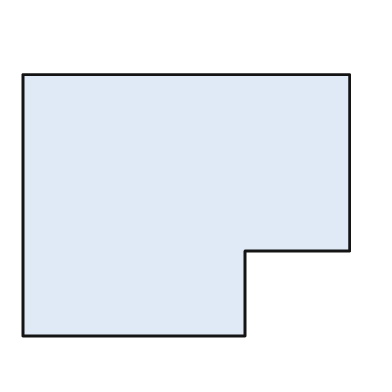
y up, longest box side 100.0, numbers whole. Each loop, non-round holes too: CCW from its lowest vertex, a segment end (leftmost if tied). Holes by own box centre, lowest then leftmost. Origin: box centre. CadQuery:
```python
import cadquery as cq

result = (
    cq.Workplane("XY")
    .moveTo(-50.0, -40.0)
    .lineTo(18.0, -40.0)
    .lineTo(18.0, -14.0)
    .lineTo(50.0, -14.0)
    .lineTo(50.0, 40.0)
    .lineTo(-50.0, 40.0)
    .close()
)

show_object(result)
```